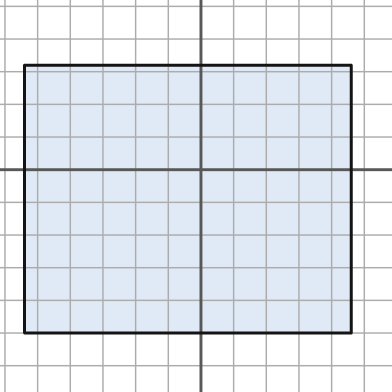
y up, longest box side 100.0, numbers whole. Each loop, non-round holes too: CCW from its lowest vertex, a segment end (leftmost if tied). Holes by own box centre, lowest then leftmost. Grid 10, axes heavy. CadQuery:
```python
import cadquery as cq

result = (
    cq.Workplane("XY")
    .moveTo(-54.0, -50.0)
    .lineTo(46.0, -50.0)
    .lineTo(46.0, 32.0)
    .lineTo(-54.0, 32.0)
    .close()
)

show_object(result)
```